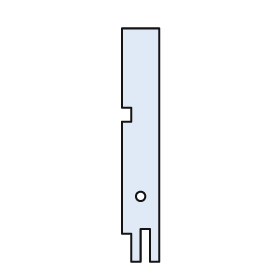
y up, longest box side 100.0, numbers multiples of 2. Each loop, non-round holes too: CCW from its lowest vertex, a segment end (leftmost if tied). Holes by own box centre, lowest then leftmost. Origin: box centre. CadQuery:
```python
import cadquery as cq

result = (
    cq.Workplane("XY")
    .moveTo(-4.0, -50.0)
    .lineTo(0.0, -50.0)
    .lineTo(0.0, -36.0)
    .lineTo(4.0, -36.0)
    .lineTo(4.0, -50.0)
    .lineTo(8.0, -50.0)
    .lineTo(8.0, 50.0)
    .lineTo(-8.0, 50.0)
    .lineTo(-8.0, 16.0)
    .lineTo(-4.0, 16.0)
    .lineTo(-4.0, 10.0)
    .lineTo(-8.0, 10.0)
    .lineTo(-8.0, -38.0)
    .lineTo(-4.0, -38.0)
    .close()
    .moveTo(0.0, -22.0)
    .circle(2.0)
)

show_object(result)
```